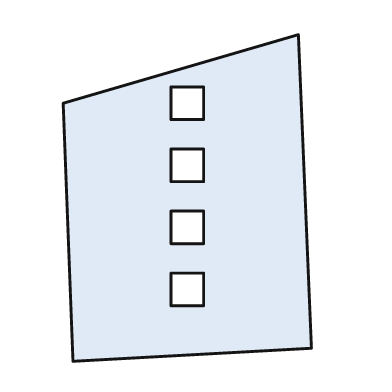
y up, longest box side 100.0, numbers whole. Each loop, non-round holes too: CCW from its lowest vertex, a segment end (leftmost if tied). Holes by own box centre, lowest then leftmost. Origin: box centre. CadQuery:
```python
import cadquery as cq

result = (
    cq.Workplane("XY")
    .moveTo(-35.0, -50.0)
    .lineTo(38.0, -46.0)
    .lineTo(34.0, 50.0)
    .lineTo(-38.0, 29.0)
    .close()
    .moveTo(-5.0, -33.0)
    .lineTo(5.0, -33.0)
    .lineTo(5.0, -23.0)
    .lineTo(-5.0, -23.0)
    .close()
    .moveTo(-5.0, -14.0)
    .lineTo(5.0, -14.0)
    .lineTo(5.0, -4.0)
    .lineTo(-5.0, -4.0)
    .close()
    .moveTo(-5.0, 5.0)
    .lineTo(5.0, 5.0)
    .lineTo(5.0, 15.0)
    .lineTo(-5.0, 15.0)
    .close()
    .moveTo(-5.0, 24.0)
    .lineTo(5.0, 24.0)
    .lineTo(5.0, 34.0)
    .lineTo(-5.0, 34.0)
    .close()
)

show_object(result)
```